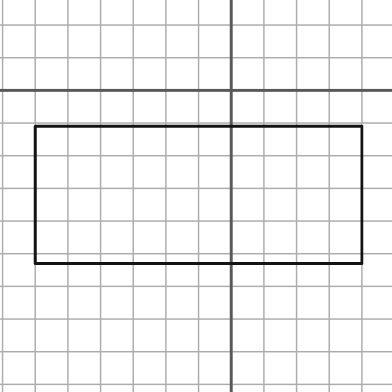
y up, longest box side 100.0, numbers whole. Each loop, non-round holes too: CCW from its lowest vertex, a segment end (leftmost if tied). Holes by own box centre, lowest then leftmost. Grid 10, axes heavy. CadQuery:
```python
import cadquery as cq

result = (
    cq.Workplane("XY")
    .moveTo(-60.0, -53.0)
    .lineTo(40.0, -53.0)
    .lineTo(40.0, -11.0)
    .lineTo(-60.0, -11.0)
    .close()
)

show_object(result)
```